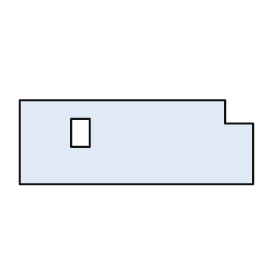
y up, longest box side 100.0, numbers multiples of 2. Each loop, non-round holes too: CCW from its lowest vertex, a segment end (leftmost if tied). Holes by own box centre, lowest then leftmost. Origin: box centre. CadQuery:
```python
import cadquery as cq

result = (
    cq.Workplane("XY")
    .moveTo(-50.0, -18.0)
    .lineTo(50.0, -18.0)
    .lineTo(50.0, 8.0)
    .lineTo(38.0, 8.0)
    .lineTo(38.0, 18.0)
    .lineTo(-50.0, 18.0)
    .close()
    .moveTo(-28.0, -2.0)
    .lineTo(-20.0, -2.0)
    .lineTo(-20.0, 10.0)
    .lineTo(-28.0, 10.0)
    .close()
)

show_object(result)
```